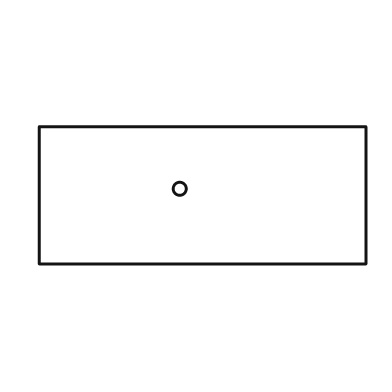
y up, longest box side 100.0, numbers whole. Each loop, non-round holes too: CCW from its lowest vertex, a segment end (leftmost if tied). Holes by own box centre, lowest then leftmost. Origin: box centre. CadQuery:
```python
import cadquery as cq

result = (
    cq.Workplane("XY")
    .moveTo(-50.0, -21.0)
    .lineTo(50.0, -21.0)
    .lineTo(50.0, 21.0)
    .lineTo(-50.0, 21.0)
    .close()
    .moveTo(-7.0, 2.0)
    .circle(2.0)
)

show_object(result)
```